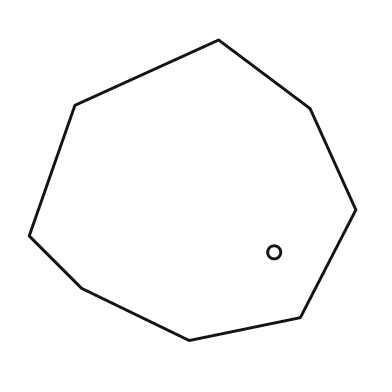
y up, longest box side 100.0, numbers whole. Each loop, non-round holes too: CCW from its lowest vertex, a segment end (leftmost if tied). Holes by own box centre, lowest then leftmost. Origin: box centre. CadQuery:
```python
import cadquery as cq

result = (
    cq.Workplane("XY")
    .moveTo(-1.0, -46.0)
    .lineTo(33.0, -39.0)
    .lineTo(50.0, -6.0)
    .lineTo(36.0, 25.0)
    .lineTo(8.0, 46.0)
    .lineTo(-36.0, 26.0)
    .lineTo(-50.0, -14.0)
    .lineTo(-34.0, -30.0)
    .close()
    .moveTo(25.0, -19.0)
    .circle(2.0)
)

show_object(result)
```